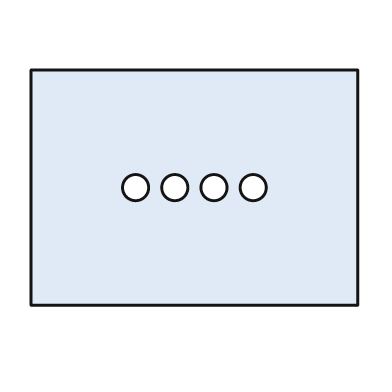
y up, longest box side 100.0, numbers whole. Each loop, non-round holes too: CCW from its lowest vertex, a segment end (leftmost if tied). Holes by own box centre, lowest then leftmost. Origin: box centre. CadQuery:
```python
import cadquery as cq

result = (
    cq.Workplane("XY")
    .moveTo(-50.0, -36.0)
    .lineTo(50.0, -36.0)
    .lineTo(50.0, 36.0)
    .lineTo(-50.0, 36.0)
    .close()
    .moveTo(-18.0, 0.0)
    .circle(4.0)
    .moveTo(-6.0, 0.0)
    .circle(4.0)
    .moveTo(6.0, 0.0)
    .circle(4.0)
    .moveTo(18.0, 0.0)
    .circle(4.0)
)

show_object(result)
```